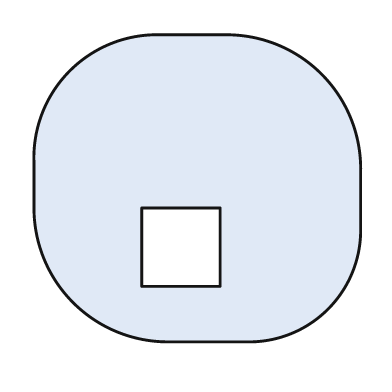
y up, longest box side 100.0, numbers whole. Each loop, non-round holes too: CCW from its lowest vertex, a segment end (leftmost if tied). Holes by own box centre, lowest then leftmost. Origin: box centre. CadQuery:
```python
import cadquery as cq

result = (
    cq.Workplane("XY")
    .moveTo(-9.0, -47.0)
    .lineTo(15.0, -47.0)
    .threePointArc((40.0, -37.0), (50.0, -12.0))
    .lineTo(50.0, 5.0)
    .threePointArc((38.0, 35.0), (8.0, 47.0))
    .lineTo(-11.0, 47.0)
    .threePointArc((-39.0, 36.0), (-50.0, 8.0))
    .lineTo(-50.0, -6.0)
    .threePointArc((-38.0, -35.0), (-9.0, -47.0))
    .close()
    .moveTo(-17.0, -30.0)
    .lineTo(7.0, -30.0)
    .lineTo(7.0, -6.0)
    .lineTo(-17.0, -6.0)
    .close()
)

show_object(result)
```